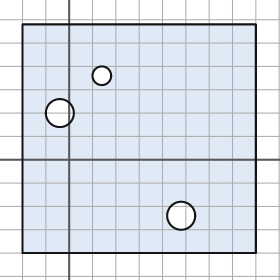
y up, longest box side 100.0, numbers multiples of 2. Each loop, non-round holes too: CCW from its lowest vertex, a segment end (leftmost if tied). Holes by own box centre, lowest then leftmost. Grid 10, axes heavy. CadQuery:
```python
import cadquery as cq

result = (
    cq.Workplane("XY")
    .moveTo(-20.0, -40.0)
    .lineTo(80.0, -40.0)
    .lineTo(80.0, 58.0)
    .lineTo(-20.0, 58.0)
    .close()
    .moveTo(48.0, -24.0)
    .circle(6.0)
    .moveTo(-4.0, 20.0)
    .circle(6.0)
    .moveTo(14.0, 36.0)
    .circle(4.0)
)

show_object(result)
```